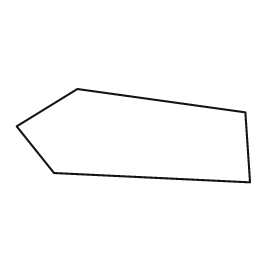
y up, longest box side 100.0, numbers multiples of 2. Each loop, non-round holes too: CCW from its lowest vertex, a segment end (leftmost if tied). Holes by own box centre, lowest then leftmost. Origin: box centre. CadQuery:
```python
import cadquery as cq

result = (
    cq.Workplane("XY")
    .moveTo(50.0, -20.0)
    .lineTo(48.0, 10.0)
    .lineTo(-24.0, 20.0)
    .lineTo(-50.0, 4.0)
    .lineTo(-34.0, -16.0)
    .close()
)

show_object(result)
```